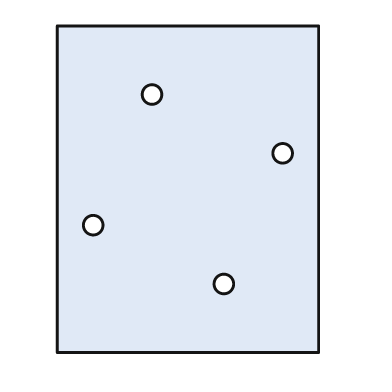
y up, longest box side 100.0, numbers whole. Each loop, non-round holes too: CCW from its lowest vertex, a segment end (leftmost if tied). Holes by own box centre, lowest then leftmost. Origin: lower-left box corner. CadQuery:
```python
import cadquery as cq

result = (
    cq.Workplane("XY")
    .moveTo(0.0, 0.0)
    .lineTo(80.0, 0.0)
    .lineTo(80.0, 100.0)
    .lineTo(0.0, 100.0)
    .close()
    .moveTo(51.0, 21.0)
    .circle(3.0)
    .moveTo(11.0, 39.0)
    .circle(3.0)
    .moveTo(69.0, 61.0)
    .circle(3.0)
    .moveTo(29.0, 79.0)
    .circle(3.0)
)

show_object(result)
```